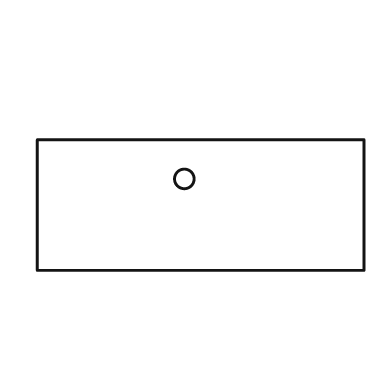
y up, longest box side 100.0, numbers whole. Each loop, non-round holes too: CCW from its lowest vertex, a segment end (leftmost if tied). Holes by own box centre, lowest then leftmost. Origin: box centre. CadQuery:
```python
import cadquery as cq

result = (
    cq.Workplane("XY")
    .moveTo(-50.0, -20.0)
    .lineTo(50.0, -20.0)
    .lineTo(50.0, 20.0)
    .lineTo(-50.0, 20.0)
    .close()
    .moveTo(-5.0, 8.0)
    .circle(3.0)
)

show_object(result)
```